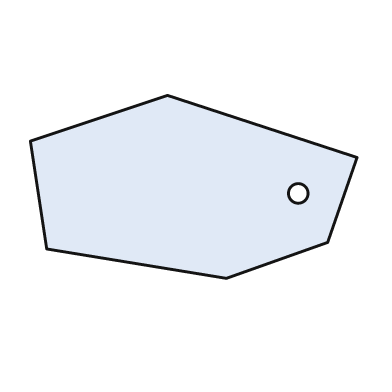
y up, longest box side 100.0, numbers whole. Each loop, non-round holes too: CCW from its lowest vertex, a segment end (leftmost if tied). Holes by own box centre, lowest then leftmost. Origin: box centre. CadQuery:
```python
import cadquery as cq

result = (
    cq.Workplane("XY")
    .moveTo(10.0, -28.0)
    .lineTo(41.0, -17.0)
    .lineTo(50.0, 9.0)
    .lineTo(-8.0, 28.0)
    .lineTo(-50.0, 14.0)
    .lineTo(-45.0, -19.0)
    .close()
    .moveTo(32.0, -2.0)
    .circle(3.0)
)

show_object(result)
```